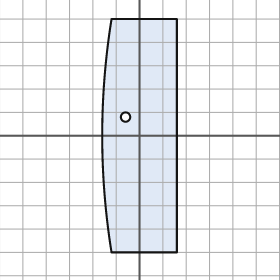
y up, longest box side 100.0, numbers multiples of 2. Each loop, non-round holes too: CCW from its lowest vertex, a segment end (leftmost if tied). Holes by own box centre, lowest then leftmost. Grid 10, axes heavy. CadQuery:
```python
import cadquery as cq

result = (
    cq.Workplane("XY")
    .moveTo(-12.0, -50.0)
    .lineTo(16.0, -50.0)
    .lineTo(16.0, 50.0)
    .lineTo(-12.0, 50.0)
    .threePointArc((-16.0, 0.0), (-12.0, -50.0))
    .close()
    .moveTo(-6.0, 8.0)
    .circle(2.0)
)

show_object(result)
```